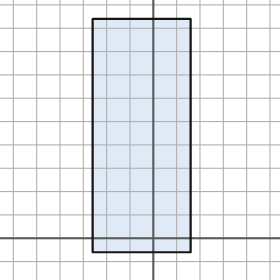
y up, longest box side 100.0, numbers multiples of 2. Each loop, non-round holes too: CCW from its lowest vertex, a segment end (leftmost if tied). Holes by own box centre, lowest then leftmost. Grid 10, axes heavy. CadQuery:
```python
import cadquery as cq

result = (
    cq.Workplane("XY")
    .moveTo(-26.0, -6.0)
    .lineTo(16.0, -6.0)
    .lineTo(16.0, 94.0)
    .lineTo(-26.0, 94.0)
    .close()
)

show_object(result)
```